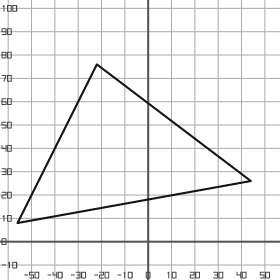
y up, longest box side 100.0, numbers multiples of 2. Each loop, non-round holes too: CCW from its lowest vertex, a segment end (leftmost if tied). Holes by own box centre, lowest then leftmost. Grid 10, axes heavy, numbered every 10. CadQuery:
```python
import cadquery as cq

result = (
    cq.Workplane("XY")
    .moveTo(-56.0, 8.0)
    .lineTo(44.0, 26.0)
    .lineTo(-22.0, 76.0)
    .close()
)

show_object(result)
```